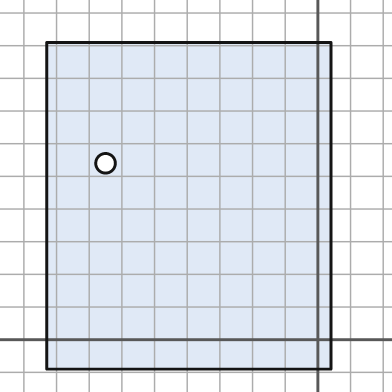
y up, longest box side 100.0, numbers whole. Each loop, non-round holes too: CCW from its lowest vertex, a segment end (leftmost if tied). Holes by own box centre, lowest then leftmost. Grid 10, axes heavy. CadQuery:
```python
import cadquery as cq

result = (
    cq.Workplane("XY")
    .moveTo(-83.0, -9.0)
    .lineTo(4.0, -9.0)
    .lineTo(4.0, 91.0)
    .lineTo(-83.0, 91.0)
    .close()
    .moveTo(-65.0, 54.0)
    .circle(3.0)
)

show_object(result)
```